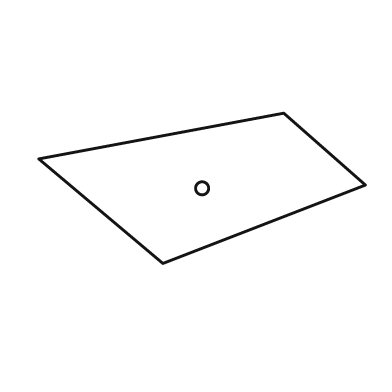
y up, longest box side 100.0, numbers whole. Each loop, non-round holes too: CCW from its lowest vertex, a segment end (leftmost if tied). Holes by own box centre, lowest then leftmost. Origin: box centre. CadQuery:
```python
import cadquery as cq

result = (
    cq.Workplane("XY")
    .moveTo(-12.0, -23.0)
    .lineTo(50.0, 1.0)
    .lineTo(25.0, 23.0)
    .lineTo(-50.0, 9.0)
    .close()
    .moveTo(0.0, 0.0)
    .circle(2.0)
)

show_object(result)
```